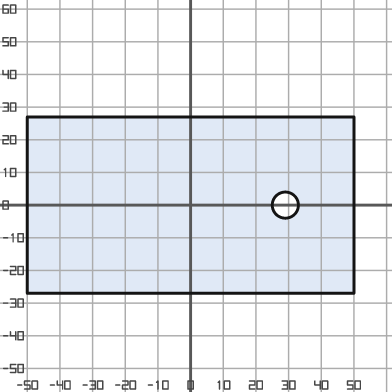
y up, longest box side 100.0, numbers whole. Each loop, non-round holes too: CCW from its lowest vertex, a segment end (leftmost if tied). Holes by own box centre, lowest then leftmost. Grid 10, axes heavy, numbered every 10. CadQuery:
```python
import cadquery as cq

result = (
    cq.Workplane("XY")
    .moveTo(-50.0, -27.0)
    .lineTo(50.0, -27.0)
    .lineTo(50.0, 27.0)
    .lineTo(-50.0, 27.0)
    .close()
    .moveTo(29.0, 0.0)
    .circle(4.0)
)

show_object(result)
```